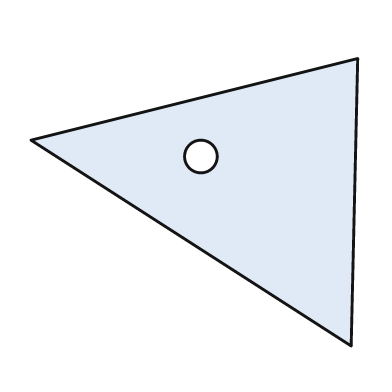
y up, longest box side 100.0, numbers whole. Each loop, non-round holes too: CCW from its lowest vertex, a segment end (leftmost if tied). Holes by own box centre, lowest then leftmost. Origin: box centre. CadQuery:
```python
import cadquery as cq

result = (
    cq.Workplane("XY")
    .moveTo(48.0, -44.0)
    .lineTo(50.0, 44.0)
    .lineTo(-50.0, 19.0)
    .close()
    .moveTo(2.0, 14.0)
    .circle(5.0)
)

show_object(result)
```